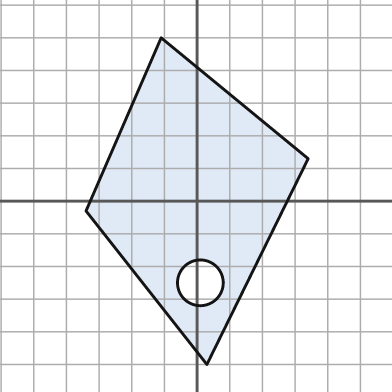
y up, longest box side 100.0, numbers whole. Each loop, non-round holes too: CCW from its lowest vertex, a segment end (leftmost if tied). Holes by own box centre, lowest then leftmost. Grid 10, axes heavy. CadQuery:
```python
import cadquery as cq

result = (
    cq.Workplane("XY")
    .moveTo(3.0, -50.0)
    .lineTo(34.0, 13.0)
    .lineTo(-11.0, 50.0)
    .lineTo(-34.0, -3.0)
    .close()
    .moveTo(1.0, -25.0)
    .circle(7.0)
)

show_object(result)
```